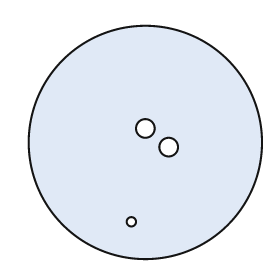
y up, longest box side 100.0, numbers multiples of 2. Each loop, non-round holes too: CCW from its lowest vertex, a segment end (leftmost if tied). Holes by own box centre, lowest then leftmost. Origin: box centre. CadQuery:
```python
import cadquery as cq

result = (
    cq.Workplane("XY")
    .moveTo(0.0, 0.0)
    .circle(50.0)
    .moveTo(-6.0, -34.0)
    .circle(2.0)
    .moveTo(10.0, -2.0)
    .circle(4.0)
    .moveTo(0.0, 6.0)
    .circle(4.0)
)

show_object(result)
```